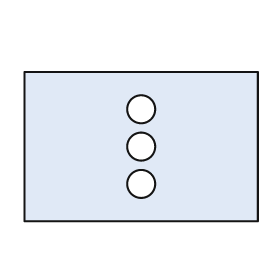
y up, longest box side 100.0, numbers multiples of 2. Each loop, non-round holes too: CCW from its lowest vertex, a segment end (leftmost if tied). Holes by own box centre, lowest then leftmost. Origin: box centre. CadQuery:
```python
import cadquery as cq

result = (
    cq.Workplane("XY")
    .moveTo(-50.0, -32.0)
    .lineTo(50.0, -32.0)
    .lineTo(50.0, 32.0)
    .lineTo(-50.0, 32.0)
    .close()
    .moveTo(0.0, -16.0)
    .circle(6.0)
    .moveTo(0.0, 0.0)
    .circle(6.0)
    .moveTo(0.0, 16.0)
    .circle(6.0)
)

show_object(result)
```